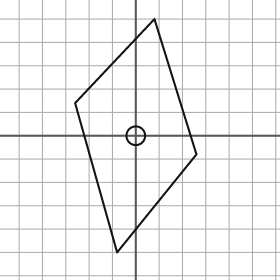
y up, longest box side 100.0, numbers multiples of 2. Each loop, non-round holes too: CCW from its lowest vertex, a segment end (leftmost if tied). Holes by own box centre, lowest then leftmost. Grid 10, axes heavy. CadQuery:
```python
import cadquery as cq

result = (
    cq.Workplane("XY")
    .moveTo(-8.0, -50.0)
    .lineTo(26.0, -8.0)
    .lineTo(8.0, 50.0)
    .lineTo(-26.0, 14.0)
    .close()
    .moveTo(0.0, 0.0)
    .circle(4.0)
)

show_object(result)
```